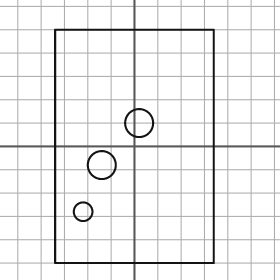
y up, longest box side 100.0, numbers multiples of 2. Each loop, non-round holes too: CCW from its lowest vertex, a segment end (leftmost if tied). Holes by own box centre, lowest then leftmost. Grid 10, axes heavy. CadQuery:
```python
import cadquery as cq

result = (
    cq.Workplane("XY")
    .moveTo(-34.0, -50.0)
    .lineTo(34.0, -50.0)
    .lineTo(34.0, 50.0)
    .lineTo(-34.0, 50.0)
    .close()
    .moveTo(-22.0, -28.0)
    .circle(4.0)
    .moveTo(-14.0, -8.0)
    .circle(6.0)
    .moveTo(2.0, 10.0)
    .circle(6.0)
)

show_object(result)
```